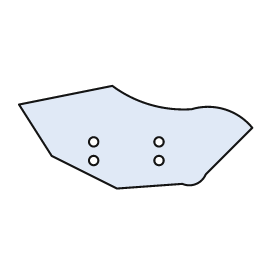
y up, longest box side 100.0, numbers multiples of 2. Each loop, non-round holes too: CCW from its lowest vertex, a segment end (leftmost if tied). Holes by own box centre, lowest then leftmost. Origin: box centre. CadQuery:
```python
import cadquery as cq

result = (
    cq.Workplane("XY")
    .moveTo(-8.0, -22.0)
    .lineTo(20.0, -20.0)
    .threePointArc((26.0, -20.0), (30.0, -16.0))
    .lineTo(50.0, 4.0)
    .threePointArc((38.0, 12.0), (24.0, 12.0))
    .threePointArc((6.0, 14.0), (-10.0, 22.0))
    .lineTo(-50.0, 14.0)
    .lineTo(-36.0, -8.0)
    .close()
    .moveTo(-18.0, -10.0)
    .circle(2.0)
    .moveTo(10.0, -10.0)
    .circle(2.0)
    .moveTo(-18.0, -2.0)
    .circle(2.0)
    .moveTo(10.0, -2.0)
    .circle(2.0)
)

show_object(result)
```